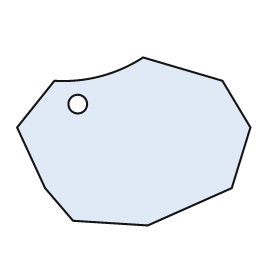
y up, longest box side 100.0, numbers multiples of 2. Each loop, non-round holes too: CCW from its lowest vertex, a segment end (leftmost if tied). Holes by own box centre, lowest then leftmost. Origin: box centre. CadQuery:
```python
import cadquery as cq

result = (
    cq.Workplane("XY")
    .moveTo(6.0, -36.0)
    .lineTo(42.0, -20.0)
    .lineTo(50.0, 6.0)
    .lineTo(38.0, 26.0)
    .lineTo(4.0, 36.0)
    .threePointArc((-14.0, 28.0), (-34.0, 26.0))
    .lineTo(-50.0, 6.0)
    .lineTo(-38.0, -20.0)
    .lineTo(-26.0, -34.0)
    .close()
    .moveTo(-24.0, 16.0)
    .circle(4.0)
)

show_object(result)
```